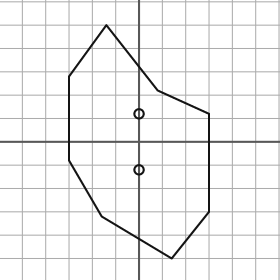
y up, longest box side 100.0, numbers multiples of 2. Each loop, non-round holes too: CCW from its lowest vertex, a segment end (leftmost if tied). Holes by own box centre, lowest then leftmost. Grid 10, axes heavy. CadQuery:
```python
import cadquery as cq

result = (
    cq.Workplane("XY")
    .moveTo(14.0, -50.0)
    .lineTo(30.0, -30.0)
    .lineTo(30.0, 12.0)
    .lineTo(8.0, 22.0)
    .lineTo(-14.0, 50.0)
    .lineTo(-30.0, 28.0)
    .lineTo(-30.0, -8.0)
    .lineTo(-16.0, -32.0)
    .close()
    .moveTo(0.0, -12.0)
    .circle(2.0)
    .moveTo(0.0, 12.0)
    .circle(2.0)
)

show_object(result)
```